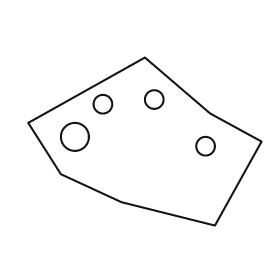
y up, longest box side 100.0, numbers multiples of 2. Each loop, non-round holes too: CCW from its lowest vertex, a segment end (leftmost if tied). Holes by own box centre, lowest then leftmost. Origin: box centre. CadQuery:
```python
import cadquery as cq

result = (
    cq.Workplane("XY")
    .moveTo(30.0, -36.0)
    .lineTo(50.0, 0.0)
    .lineTo(28.0, 12.0)
    .lineTo(0.0, 36.0)
    .lineTo(-50.0, 8.0)
    .lineTo(-36.0, -14.0)
    .lineTo(-10.0, -26.0)
    .close()
    .moveTo(26.0, -2.0)
    .circle(4.0)
    .moveTo(-30.0, 2.0)
    .circle(6.0)
    .moveTo(-18.0, 16.0)
    .circle(4.0)
    .moveTo(4.0, 18.0)
    .circle(4.0)
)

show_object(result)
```